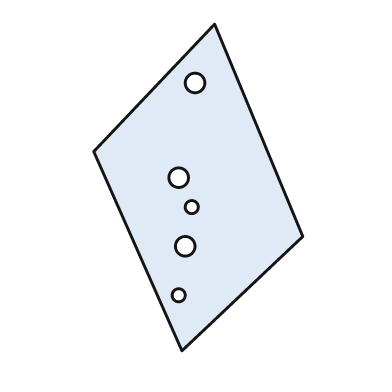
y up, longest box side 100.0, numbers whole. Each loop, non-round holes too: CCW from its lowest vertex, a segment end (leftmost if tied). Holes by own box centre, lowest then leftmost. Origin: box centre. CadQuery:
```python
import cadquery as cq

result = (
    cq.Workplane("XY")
    .moveTo(-5.0, -50.0)
    .lineTo(32.0, -15.0)
    .lineTo(5.0, 50.0)
    .lineTo(-32.0, 11.0)
    .close()
    .moveTo(-6.0, -33.0)
    .circle(2.0)
    .moveTo(-4.0, -18.0)
    .circle(3.0)
    .moveTo(-2.0, -6.0)
    .circle(2.0)
    .moveTo(-6.0, 3.0)
    .circle(3.0)
    .moveTo(-1.0, 32.0)
    .circle(3.0)
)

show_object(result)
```